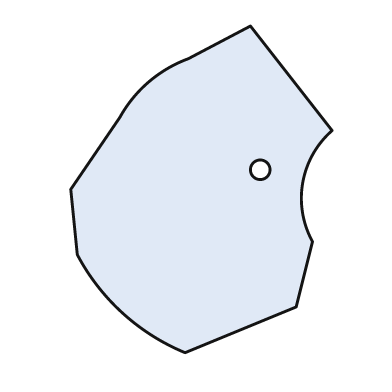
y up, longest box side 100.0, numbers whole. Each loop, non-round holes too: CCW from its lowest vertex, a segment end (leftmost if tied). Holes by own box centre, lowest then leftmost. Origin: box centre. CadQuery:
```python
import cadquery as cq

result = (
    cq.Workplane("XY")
    .moveTo(-5.0, -50.0)
    .lineTo(29.0, -36.0)
    .lineTo(34.0, -16.0)
    .threePointArc((31.0, 2.0), (40.0, 18.0))
    .lineTo(15.0, 50.0)
    .lineTo(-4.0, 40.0)
    .threePointArc((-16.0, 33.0), (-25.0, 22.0))
    .lineTo(-40.0, 0.0)
    .lineTo(-38.0, -20.0)
    .threePointArc((-24.0, -38.0), (-5.0, -50.0))
    .close()
    .moveTo(18.0, 6.0)
    .circle(3.0)
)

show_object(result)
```